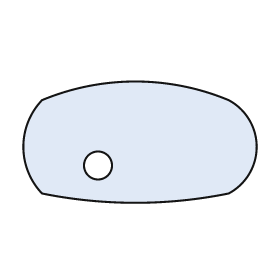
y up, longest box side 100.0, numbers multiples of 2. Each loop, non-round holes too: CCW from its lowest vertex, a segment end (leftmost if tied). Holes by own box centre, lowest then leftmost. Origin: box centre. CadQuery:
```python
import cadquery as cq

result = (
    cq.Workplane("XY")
    .moveTo(-42.0, -22.0)
    .threePointArc((-2.0, -26.0), (38.0, -22.0))
    .threePointArc((50.0, -2.0), (38.0, 18.0))
    .threePointArc((-2.0, 26.0), (-42.0, 18.0))
    .threePointArc((-50.0, -2.0), (-42.0, -22.0))
    .close()
    .moveTo(-18.0, -10.0)
    .circle(6.0)
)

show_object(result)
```